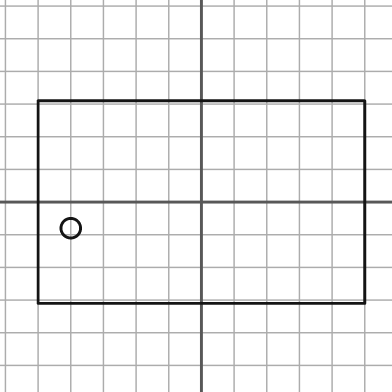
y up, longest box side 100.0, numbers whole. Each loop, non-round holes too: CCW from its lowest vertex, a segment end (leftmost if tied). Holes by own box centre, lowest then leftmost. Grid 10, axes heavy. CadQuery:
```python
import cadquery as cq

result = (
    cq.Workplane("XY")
    .moveTo(-50.0, -31.0)
    .lineTo(50.0, -31.0)
    .lineTo(50.0, 31.0)
    .lineTo(-50.0, 31.0)
    .close()
    .moveTo(-40.0, -8.0)
    .circle(3.0)
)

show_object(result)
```